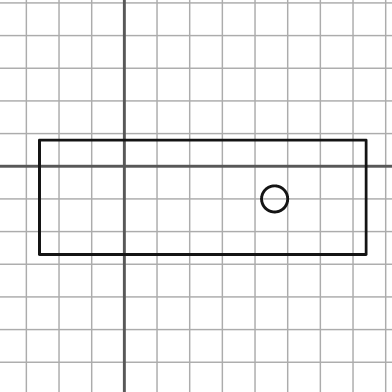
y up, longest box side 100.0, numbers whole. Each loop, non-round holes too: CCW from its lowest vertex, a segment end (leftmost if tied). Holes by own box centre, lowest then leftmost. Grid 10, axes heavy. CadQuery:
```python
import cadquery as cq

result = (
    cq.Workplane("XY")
    .moveTo(-26.0, -27.0)
    .lineTo(74.0, -27.0)
    .lineTo(74.0, 8.0)
    .lineTo(-26.0, 8.0)
    .close()
    .moveTo(46.0, -10.0)
    .circle(4.0)
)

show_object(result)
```